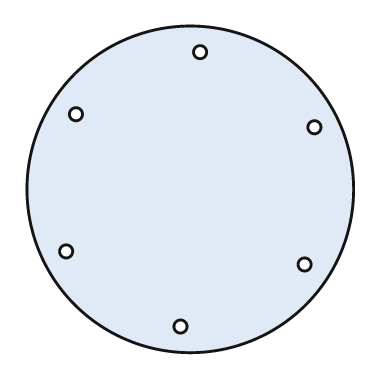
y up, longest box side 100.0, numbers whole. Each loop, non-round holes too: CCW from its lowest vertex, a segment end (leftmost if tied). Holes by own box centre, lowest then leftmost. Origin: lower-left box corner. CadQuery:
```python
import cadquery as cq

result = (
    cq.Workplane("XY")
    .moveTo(50.0, 50.0)
    .circle(50.0)
    .moveTo(47.0, 8.0)
    .circle(2.0)
    .moveTo(85.0, 27.0)
    .circle(2.0)
    .moveTo(12.0, 31.0)
    .circle(2.0)
    .moveTo(88.0, 69.0)
    .circle(2.0)
    .moveTo(15.0, 73.0)
    .circle(2.0)
    .moveTo(53.0, 92.0)
    .circle(2.0)
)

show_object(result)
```